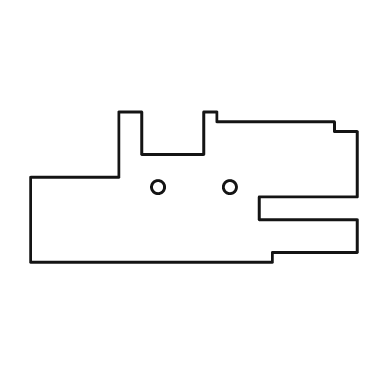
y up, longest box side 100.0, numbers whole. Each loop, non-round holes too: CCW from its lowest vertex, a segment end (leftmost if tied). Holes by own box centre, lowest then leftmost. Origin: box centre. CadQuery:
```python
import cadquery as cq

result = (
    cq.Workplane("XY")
    .moveTo(-50.0, -23.0)
    .lineTo(24.0, -23.0)
    .lineTo(24.0, -20.0)
    .lineTo(50.0, -20.0)
    .lineTo(50.0, -10.0)
    .lineTo(20.0, -10.0)
    .lineTo(20.0, -3.0)
    .lineTo(50.0, -3.0)
    .lineTo(50.0, 17.0)
    .lineTo(43.0, 17.0)
    .lineTo(43.0, 20.0)
    .lineTo(7.0, 20.0)
    .lineTo(7.0, 23.0)
    .lineTo(3.0, 23.0)
    .lineTo(3.0, 10.0)
    .lineTo(-16.0, 10.0)
    .lineTo(-16.0, 23.0)
    .lineTo(-23.0, 23.0)
    .lineTo(-23.0, 3.0)
    .lineTo(-50.0, 3.0)
    .close()
    .moveTo(-11.0, 0.0)
    .circle(2.0)
    .moveTo(11.0, 0.0)
    .circle(2.0)
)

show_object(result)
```